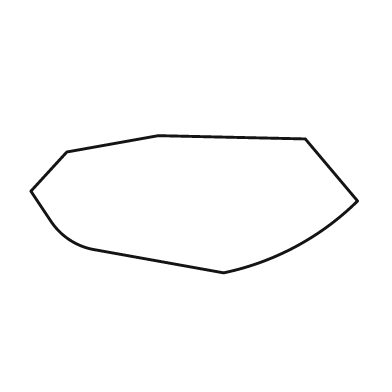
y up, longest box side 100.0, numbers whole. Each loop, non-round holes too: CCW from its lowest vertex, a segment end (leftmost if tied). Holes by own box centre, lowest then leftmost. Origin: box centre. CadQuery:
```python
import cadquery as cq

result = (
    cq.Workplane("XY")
    .moveTo(9.0, -21.0)
    .threePointArc((31.0, -13.0), (50.0, 1.0))
    .lineTo(34.0, 20.0)
    .lineTo(-11.0, 21.0)
    .lineTo(-39.0, 16.0)
    .lineTo(-50.0, 4.0)
    .lineTo(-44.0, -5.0)
    .threePointArc((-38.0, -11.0), (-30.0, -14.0))
    .close()
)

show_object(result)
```